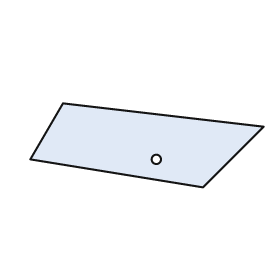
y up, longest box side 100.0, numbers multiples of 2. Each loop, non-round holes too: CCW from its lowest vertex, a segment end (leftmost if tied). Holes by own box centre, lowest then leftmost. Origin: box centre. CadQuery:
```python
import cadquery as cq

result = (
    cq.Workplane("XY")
    .moveTo(24.0, -18.0)
    .lineTo(50.0, 8.0)
    .lineTo(-36.0, 18.0)
    .lineTo(-50.0, -6.0)
    .close()
    .moveTo(4.0, -6.0)
    .circle(2.0)
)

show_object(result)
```